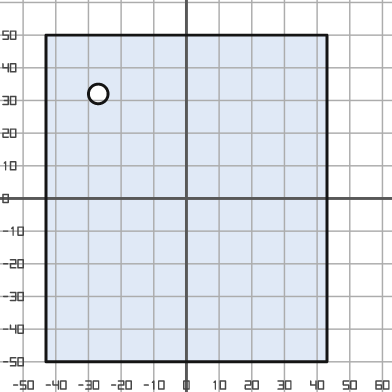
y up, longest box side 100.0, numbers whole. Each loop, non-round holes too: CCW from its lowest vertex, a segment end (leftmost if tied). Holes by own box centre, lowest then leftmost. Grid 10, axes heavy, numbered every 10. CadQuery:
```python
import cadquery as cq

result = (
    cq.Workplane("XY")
    .moveTo(-43.0, -50.0)
    .lineTo(43.0, -50.0)
    .lineTo(43.0, 50.0)
    .lineTo(-43.0, 50.0)
    .close()
    .moveTo(-27.0, 32.0)
    .circle(3.0)
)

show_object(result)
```